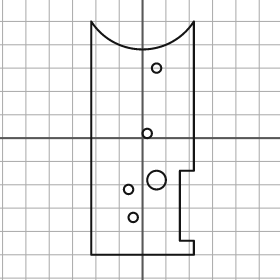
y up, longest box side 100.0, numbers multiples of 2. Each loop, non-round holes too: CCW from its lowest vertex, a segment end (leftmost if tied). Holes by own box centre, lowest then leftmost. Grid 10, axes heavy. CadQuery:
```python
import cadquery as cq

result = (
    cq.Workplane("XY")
    .moveTo(-22.0, -50.0)
    .lineTo(22.0, -50.0)
    .lineTo(22.0, -44.0)
    .lineTo(16.0, -44.0)
    .lineTo(16.0, -14.0)
    .lineTo(22.0, -14.0)
    .lineTo(22.0, 50.0)
    .threePointArc((0.0, 38.0), (-22.0, 50.0))
    .close()
    .moveTo(-4.0, -34.0)
    .circle(2.0)
    .moveTo(-6.0, -22.0)
    .circle(2.0)
    .moveTo(6.0, -18.0)
    .circle(4.0)
    .moveTo(2.0, 2.0)
    .circle(2.0)
    .moveTo(6.0, 30.0)
    .circle(2.0)
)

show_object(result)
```